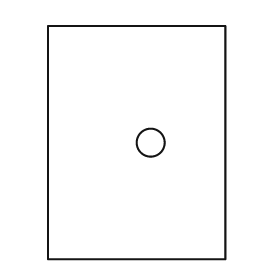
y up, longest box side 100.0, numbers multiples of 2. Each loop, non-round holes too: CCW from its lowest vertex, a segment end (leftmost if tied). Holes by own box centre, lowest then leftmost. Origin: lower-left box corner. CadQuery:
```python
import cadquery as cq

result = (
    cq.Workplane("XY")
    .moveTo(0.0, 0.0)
    .lineTo(76.0, 0.0)
    .lineTo(76.0, 100.0)
    .lineTo(0.0, 100.0)
    .close()
    .moveTo(44.0, 50.0)
    .circle(6.0)
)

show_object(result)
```